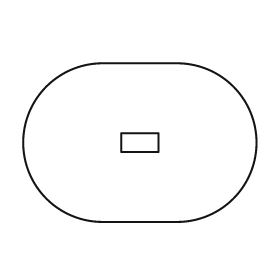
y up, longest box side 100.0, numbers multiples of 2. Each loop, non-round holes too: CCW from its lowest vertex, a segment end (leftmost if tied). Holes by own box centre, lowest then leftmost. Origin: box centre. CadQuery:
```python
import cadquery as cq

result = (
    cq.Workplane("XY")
    .moveTo(-16.0, -34.0)
    .lineTo(16.0, -34.0)
    .threePointArc((50.0, 0.0), (16.0, 34.0))
    .lineTo(-16.0, 34.0)
    .threePointArc((-50.0, 0.0), (-16.0, -34.0))
    .close()
    .moveTo(-8.0, -4.0)
    .lineTo(8.0, -4.0)
    .lineTo(8.0, 4.0)
    .lineTo(-8.0, 4.0)
    .close()
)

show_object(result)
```